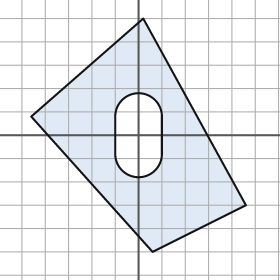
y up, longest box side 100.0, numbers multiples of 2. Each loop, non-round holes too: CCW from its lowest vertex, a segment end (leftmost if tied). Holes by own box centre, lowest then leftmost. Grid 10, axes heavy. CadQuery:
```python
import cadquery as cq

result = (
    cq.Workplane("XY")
    .moveTo(6.0, -50.0)
    .lineTo(46.0, -30.0)
    .lineTo(2.0, 50.0)
    .lineTo(-46.0, 8.0)
    .close()
    .moveTo(-10.0, -8.0)
    .threePointArc((0.0, -18.0), (10.0, -8.0))
    .lineTo(10.0, 8.0)
    .threePointArc((0.0, 18.0), (-10.0, 8.0))
    .close()
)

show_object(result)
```